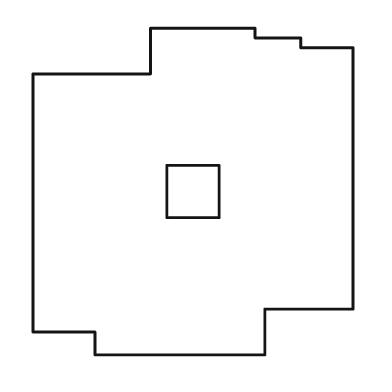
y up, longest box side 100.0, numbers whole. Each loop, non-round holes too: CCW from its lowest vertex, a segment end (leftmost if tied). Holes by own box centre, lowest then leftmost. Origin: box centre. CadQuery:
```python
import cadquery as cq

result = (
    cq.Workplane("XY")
    .moveTo(-30.0, -50.0)
    .lineTo(22.0, -50.0)
    .lineTo(22.0, -36.0)
    .lineTo(49.0, -36.0)
    .lineTo(49.0, 44.0)
    .lineTo(33.0, 44.0)
    .lineTo(33.0, 47.0)
    .lineTo(19.0, 47.0)
    .lineTo(19.0, 50.0)
    .lineTo(-13.0, 50.0)
    .lineTo(-13.0, 36.0)
    .lineTo(-49.0, 36.0)
    .lineTo(-49.0, -43.0)
    .lineTo(-30.0, -43.0)
    .close()
    .moveTo(-8.0, -8.0)
    .lineTo(8.0, -8.0)
    .lineTo(8.0, 8.0)
    .lineTo(-8.0, 8.0)
    .close()
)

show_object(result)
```